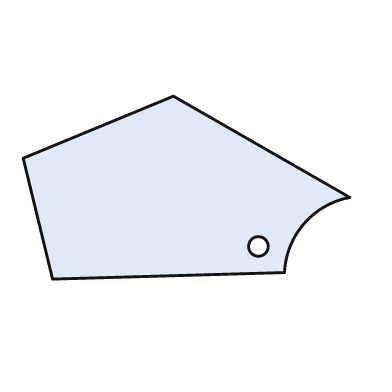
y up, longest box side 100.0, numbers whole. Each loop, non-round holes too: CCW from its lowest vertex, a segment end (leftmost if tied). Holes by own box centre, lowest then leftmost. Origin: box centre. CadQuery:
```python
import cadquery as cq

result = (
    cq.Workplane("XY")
    .moveTo(-41.0, -28.0)
    .lineTo(30.0, -26.0)
    .threePointArc((36.0, -11.0), (50.0, -3.0))
    .lineTo(-4.0, 28.0)
    .lineTo(-50.0, 9.0)
    .close()
    .moveTo(22.0, -18.0)
    .circle(3.0)
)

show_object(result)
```